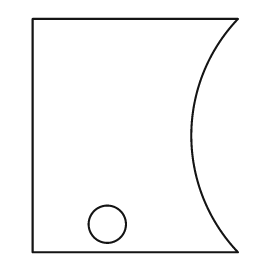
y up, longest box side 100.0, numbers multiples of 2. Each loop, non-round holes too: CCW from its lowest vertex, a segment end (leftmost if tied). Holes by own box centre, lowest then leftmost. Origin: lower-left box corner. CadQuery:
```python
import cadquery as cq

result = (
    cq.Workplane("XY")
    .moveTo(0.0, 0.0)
    .lineTo(88.0, 0.0)
    .threePointArc((68.0, 50.0), (88.0, 100.0))
    .lineTo(0.0, 100.0)
    .close()
    .moveTo(32.0, 12.0)
    .circle(8.0)
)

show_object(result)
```